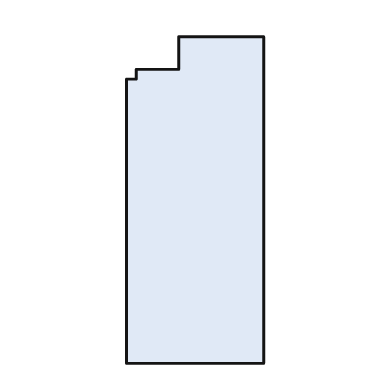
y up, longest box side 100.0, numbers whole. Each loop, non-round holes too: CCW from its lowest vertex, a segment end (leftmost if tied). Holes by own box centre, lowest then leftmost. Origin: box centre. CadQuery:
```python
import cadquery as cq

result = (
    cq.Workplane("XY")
    .moveTo(-21.0, -50.0)
    .lineTo(21.0, -50.0)
    .lineTo(21.0, 50.0)
    .lineTo(-5.0, 50.0)
    .lineTo(-5.0, 40.0)
    .lineTo(-18.0, 40.0)
    .lineTo(-18.0, 37.0)
    .lineTo(-21.0, 37.0)
    .close()
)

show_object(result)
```